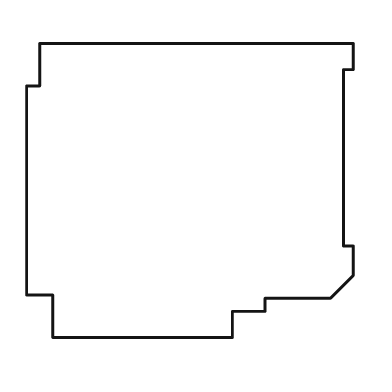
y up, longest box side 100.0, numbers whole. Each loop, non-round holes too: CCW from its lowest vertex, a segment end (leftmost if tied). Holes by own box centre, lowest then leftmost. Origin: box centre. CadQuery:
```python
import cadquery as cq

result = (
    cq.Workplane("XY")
    .moveTo(-42.0, -45.0)
    .lineTo(13.0, -45.0)
    .lineTo(13.0, -37.0)
    .lineTo(23.0, -37.0)
    .lineTo(23.0, -33.0)
    .lineTo(43.0, -33.0)
    .lineTo(50.0, -26.0)
    .lineTo(50.0, -17.0)
    .lineTo(47.0, -17.0)
    .lineTo(47.0, 37.0)
    .lineTo(50.0, 37.0)
    .lineTo(50.0, 45.0)
    .lineTo(-46.0, 45.0)
    .lineTo(-46.0, 32.0)
    .lineTo(-50.0, 32.0)
    .lineTo(-50.0, -32.0)
    .lineTo(-42.0, -32.0)
    .close()
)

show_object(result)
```